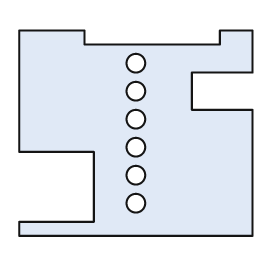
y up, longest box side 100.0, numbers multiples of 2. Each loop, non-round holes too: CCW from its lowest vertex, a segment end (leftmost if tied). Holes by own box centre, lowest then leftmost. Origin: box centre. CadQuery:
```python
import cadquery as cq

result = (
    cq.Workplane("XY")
    .moveTo(-50.0, -44.0)
    .lineTo(50.0, -44.0)
    .lineTo(50.0, 10.0)
    .lineTo(24.0, 10.0)
    .lineTo(24.0, 26.0)
    .lineTo(50.0, 26.0)
    .lineTo(50.0, 44.0)
    .lineTo(36.0, 44.0)
    .lineTo(36.0, 38.0)
    .lineTo(-22.0, 38.0)
    .lineTo(-22.0, 44.0)
    .lineTo(-50.0, 44.0)
    .lineTo(-50.0, -8.0)
    .lineTo(-18.0, -8.0)
    .lineTo(-18.0, -38.0)
    .lineTo(-50.0, -38.0)
    .close()
    .moveTo(0.0, -30.0)
    .circle(4.0)
    .moveTo(0.0, -18.0)
    .circle(4.0)
    .moveTo(0.0, -6.0)
    .circle(4.0)
    .moveTo(0.0, 6.0)
    .circle(4.0)
    .moveTo(0.0, 18.0)
    .circle(4.0)
    .moveTo(0.0, 30.0)
    .circle(4.0)
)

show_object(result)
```